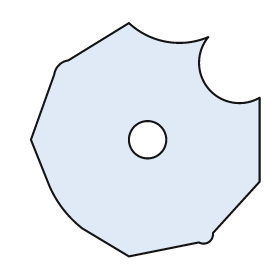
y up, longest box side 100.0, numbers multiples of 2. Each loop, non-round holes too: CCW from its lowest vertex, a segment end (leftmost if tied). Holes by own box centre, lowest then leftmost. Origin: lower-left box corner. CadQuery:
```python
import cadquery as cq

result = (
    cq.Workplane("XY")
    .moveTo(42.0, 0.0)
    .lineTo(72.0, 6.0)
    .threePointArc((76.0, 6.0), (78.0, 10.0))
    .lineTo(98.0, 32.0)
    .lineTo(98.0, 68.0)
    .threePointArc((76.0, 72.0), (76.0, 94.0))
    .threePointArc((58.0, 92.0), (42.0, 100.0))
    .lineTo(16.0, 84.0)
    .threePointArc((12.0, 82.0), (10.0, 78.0))
    .lineTo(0.0, 50.0)
    .lineTo(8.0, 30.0)
    .threePointArc((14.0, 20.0), (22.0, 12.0))
    .close()
    .moveTo(50.0, 50.0)
    .circle(8.0)
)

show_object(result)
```